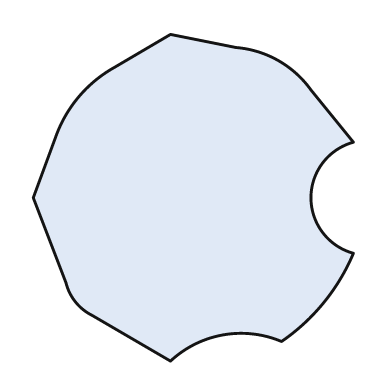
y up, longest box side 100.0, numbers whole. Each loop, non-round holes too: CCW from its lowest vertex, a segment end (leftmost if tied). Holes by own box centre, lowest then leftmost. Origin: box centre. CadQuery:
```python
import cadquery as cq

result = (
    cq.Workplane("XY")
    .moveTo(-7.0, -50.0)
    .threePointArc((9.0, -42.0), (27.0, -44.0))
    .threePointArc((40.0, -32.0), (49.0, -17.0))
    .threePointArc((36.0, 0.0), (49.0, 17.0))
    .lineTo(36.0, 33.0)
    .threePointArc((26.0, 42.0), (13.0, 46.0))
    .lineTo(-7.0, 50.0)
    .lineTo(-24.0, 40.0)
    .threePointArc((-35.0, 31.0), (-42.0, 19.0))
    .lineTo(-49.0, 0.0)
    .lineTo(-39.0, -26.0)
    .threePointArc((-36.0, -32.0), (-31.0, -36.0))
    .close()
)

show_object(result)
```